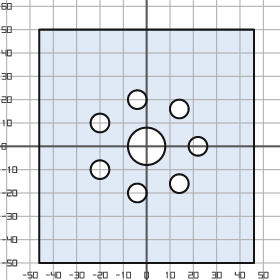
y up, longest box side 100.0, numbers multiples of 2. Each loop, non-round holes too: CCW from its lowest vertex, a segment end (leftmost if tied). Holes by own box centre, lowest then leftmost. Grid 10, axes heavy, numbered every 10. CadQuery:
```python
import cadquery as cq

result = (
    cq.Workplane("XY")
    .moveTo(-46.0, -50.0)
    .lineTo(46.0, -50.0)
    .lineTo(46.0, 50.0)
    .lineTo(-46.0, 50.0)
    .close()
    .moveTo(-4.0, -20.0)
    .circle(4.0)
    .moveTo(14.0, -16.0)
    .circle(4.0)
    .moveTo(-20.0, -10.0)
    .circle(4.0)
    .moveTo(0.0, 0.0)
    .circle(8.0)
    .moveTo(22.0, 0.0)
    .circle(4.0)
    .moveTo(-20.0, 10.0)
    .circle(4.0)
    .moveTo(14.0, 16.0)
    .circle(4.0)
    .moveTo(-4.0, 20.0)
    .circle(4.0)
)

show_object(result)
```